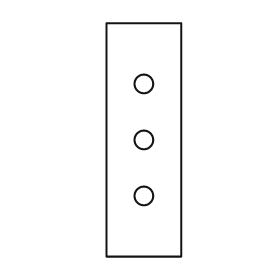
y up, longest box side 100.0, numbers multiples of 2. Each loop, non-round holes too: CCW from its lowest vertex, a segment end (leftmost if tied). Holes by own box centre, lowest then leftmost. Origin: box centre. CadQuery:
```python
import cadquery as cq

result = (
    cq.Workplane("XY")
    .moveTo(-16.0, -50.0)
    .lineTo(16.0, -50.0)
    .lineTo(16.0, 50.0)
    .lineTo(-16.0, 50.0)
    .close()
    .moveTo(0.0, -24.0)
    .circle(4.0)
    .moveTo(0.0, 0.0)
    .circle(4.0)
    .moveTo(0.0, 24.0)
    .circle(4.0)
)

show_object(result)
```